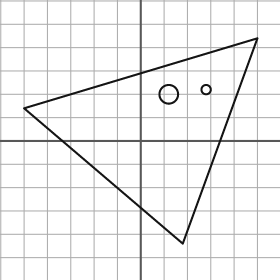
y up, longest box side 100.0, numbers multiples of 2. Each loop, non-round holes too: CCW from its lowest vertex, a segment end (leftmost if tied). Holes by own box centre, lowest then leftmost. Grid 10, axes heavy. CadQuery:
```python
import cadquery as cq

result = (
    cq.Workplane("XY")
    .moveTo(18.0, -44.0)
    .lineTo(50.0, 44.0)
    .lineTo(-50.0, 14.0)
    .close()
    .moveTo(12.0, 20.0)
    .circle(4.0)
    .moveTo(28.0, 22.0)
    .circle(2.0)
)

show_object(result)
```